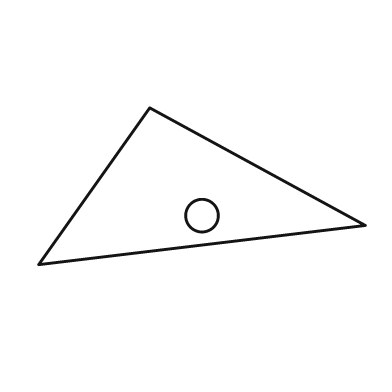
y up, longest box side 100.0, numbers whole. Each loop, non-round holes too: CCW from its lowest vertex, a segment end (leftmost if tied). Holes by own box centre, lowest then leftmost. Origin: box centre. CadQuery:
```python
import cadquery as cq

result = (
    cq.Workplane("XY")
    .moveTo(-50.0, -24.0)
    .lineTo(50.0, -12.0)
    .lineTo(-16.0, 24.0)
    .close()
    .moveTo(0.0, -9.0)
    .circle(5.0)
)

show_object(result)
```